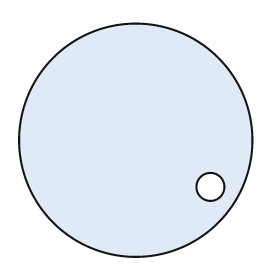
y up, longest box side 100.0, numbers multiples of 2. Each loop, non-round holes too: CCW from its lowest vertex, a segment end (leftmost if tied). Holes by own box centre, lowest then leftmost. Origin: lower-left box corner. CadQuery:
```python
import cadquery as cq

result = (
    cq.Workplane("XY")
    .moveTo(50.0, 50.0)
    .circle(50.0)
    .moveTo(82.0, 30.0)
    .circle(6.0)
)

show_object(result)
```